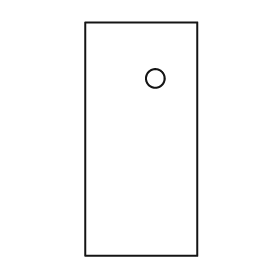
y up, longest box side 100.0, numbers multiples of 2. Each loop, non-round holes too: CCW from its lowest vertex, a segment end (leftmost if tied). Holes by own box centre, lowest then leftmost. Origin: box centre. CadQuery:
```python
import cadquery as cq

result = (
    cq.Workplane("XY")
    .moveTo(-24.0, -50.0)
    .lineTo(24.0, -50.0)
    .lineTo(24.0, 50.0)
    .lineTo(-24.0, 50.0)
    .close()
    .moveTo(6.0, 26.0)
    .circle(4.0)
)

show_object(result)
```